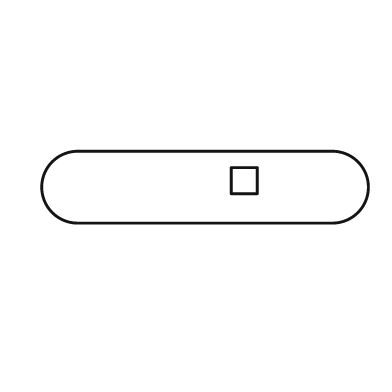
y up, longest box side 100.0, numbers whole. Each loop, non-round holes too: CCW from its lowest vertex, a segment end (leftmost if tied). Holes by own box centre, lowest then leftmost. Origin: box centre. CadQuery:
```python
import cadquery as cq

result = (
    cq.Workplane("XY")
    .moveTo(-39.0, -11.0)
    .lineTo(39.0, -11.0)
    .threePointArc((50.0, 0.0), (39.0, 11.0))
    .lineTo(-39.0, 11.0)
    .threePointArc((-50.0, 0.0), (-39.0, -11.0))
    .close()
    .moveTo(8.0, -2.0)
    .lineTo(16.0, -2.0)
    .lineTo(16.0, 6.0)
    .lineTo(8.0, 6.0)
    .close()
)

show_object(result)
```